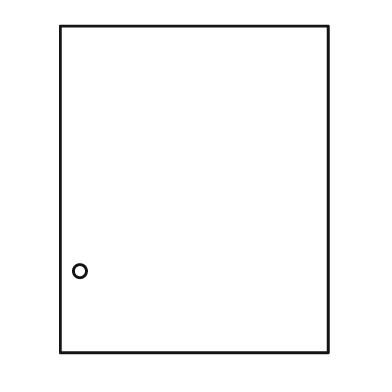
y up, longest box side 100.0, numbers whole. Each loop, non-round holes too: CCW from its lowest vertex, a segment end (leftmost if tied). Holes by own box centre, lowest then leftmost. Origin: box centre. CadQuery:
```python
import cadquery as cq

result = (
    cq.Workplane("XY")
    .moveTo(-41.0, -50.0)
    .lineTo(41.0, -50.0)
    .lineTo(41.0, 50.0)
    .lineTo(-41.0, 50.0)
    .close()
    .moveTo(-35.0, -25.0)
    .circle(2.0)
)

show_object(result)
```